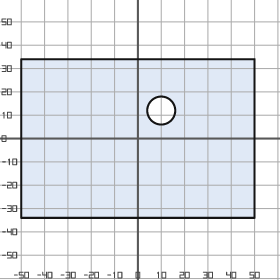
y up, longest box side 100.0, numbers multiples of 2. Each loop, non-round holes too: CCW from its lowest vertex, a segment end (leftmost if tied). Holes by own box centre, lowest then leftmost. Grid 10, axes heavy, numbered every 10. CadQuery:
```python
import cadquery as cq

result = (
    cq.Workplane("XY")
    .moveTo(-50.0, -34.0)
    .lineTo(50.0, -34.0)
    .lineTo(50.0, 34.0)
    .lineTo(-50.0, 34.0)
    .close()
    .moveTo(10.0, 12.0)
    .circle(6.0)
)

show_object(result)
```